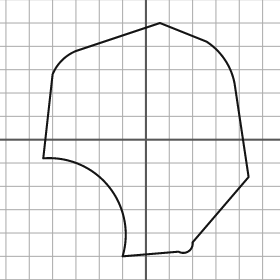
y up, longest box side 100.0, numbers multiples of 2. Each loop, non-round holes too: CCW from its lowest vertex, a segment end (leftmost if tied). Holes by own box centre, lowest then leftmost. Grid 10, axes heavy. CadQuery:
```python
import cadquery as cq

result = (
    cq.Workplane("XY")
    .moveTo(-10.0, -50.0)
    .lineTo(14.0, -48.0)
    .threePointArc((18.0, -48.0), (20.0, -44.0))
    .lineTo(44.0, -16.0)
    .lineTo(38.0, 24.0)
    .threePointArc((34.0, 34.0), (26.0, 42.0))
    .lineTo(6.0, 50.0)
    .lineTo(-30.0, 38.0)
    .threePointArc((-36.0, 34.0), (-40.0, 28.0))
    .lineTo(-44.0, -8.0)
    .threePointArc((-16.0, -20.0), (-10.0, -50.0))
    .close()
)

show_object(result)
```